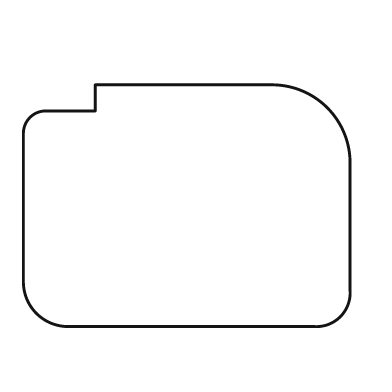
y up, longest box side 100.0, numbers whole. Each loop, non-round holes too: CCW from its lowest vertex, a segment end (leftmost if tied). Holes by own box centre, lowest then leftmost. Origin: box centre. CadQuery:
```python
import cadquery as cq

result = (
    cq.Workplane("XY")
    .moveTo(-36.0, -37.0)
    .lineTo(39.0, -37.0)
    .threePointArc((47.0, -34.0), (50.0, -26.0))
    .lineTo(50.0, 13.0)
    .threePointArc((43.0, 30.0), (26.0, 37.0))
    .lineTo(-28.0, 37.0)
    .lineTo(-28.0, 29.0)
    .lineTo(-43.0, 29.0)
    .threePointArc((-48.0, 27.0), (-50.0, 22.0))
    .lineTo(-50.0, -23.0)
    .threePointArc((-46.0, -33.0), (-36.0, -37.0))
    .close()
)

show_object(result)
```